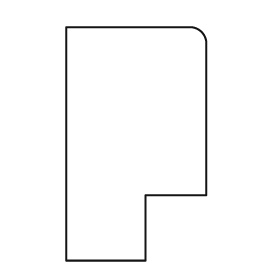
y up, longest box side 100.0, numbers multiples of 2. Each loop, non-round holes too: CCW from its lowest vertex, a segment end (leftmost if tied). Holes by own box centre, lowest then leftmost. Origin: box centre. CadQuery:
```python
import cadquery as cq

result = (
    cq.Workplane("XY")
    .moveTo(-30.0, -50.0)
    .lineTo(4.0, -50.0)
    .lineTo(4.0, -22.0)
    .lineTo(30.0, -22.0)
    .lineTo(30.0, 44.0)
    .threePointArc((28.0, 48.0), (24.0, 50.0))
    .lineTo(-30.0, 50.0)
    .close()
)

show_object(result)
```